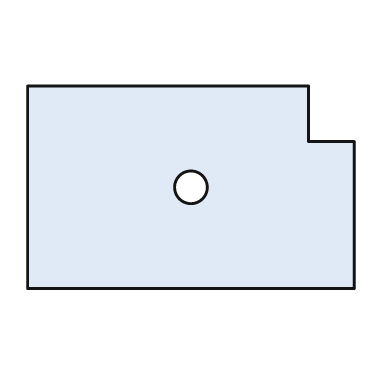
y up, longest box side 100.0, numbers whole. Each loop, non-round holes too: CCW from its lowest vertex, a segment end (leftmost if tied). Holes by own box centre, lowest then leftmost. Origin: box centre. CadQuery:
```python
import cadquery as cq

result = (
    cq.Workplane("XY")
    .moveTo(-50.0, -31.0)
    .lineTo(50.0, -31.0)
    .lineTo(50.0, 14.0)
    .lineTo(36.0, 14.0)
    .lineTo(36.0, 31.0)
    .lineTo(-50.0, 31.0)
    .close()
    .moveTo(0.0, 0.0)
    .circle(5.0)
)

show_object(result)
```